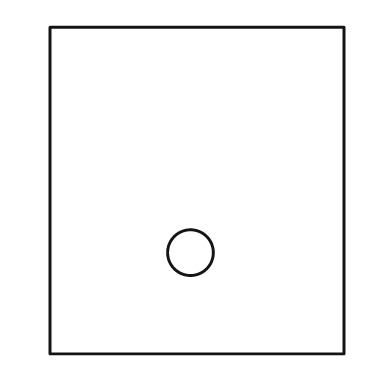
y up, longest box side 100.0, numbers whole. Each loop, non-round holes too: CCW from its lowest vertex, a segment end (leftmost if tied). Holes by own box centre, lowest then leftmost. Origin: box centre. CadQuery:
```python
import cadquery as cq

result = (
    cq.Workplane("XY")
    .moveTo(-45.0, -50.0)
    .lineTo(45.0, -50.0)
    .lineTo(45.0, 50.0)
    .lineTo(-45.0, 50.0)
    .close()
    .moveTo(-2.0, -19.0)
    .circle(7.0)
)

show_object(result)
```